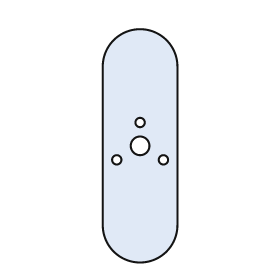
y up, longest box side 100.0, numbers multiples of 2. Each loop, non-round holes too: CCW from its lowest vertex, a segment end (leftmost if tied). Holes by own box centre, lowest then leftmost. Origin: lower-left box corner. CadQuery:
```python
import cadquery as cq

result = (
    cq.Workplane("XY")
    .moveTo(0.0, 16.0)
    .threePointArc((16.0, 0.0), (32.0, 16.0))
    .lineTo(32.0, 84.0)
    .threePointArc((16.0, 100.0), (0.0, 84.0))
    .close()
    .moveTo(6.0, 44.0)
    .circle(2.0)
    .moveTo(26.0, 44.0)
    .circle(2.0)
    .moveTo(16.0, 50.0)
    .circle(4.0)
    .moveTo(16.0, 60.0)
    .circle(2.0)
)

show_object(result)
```